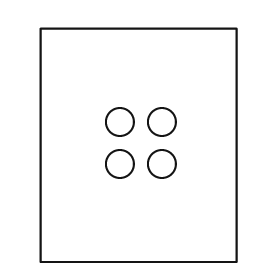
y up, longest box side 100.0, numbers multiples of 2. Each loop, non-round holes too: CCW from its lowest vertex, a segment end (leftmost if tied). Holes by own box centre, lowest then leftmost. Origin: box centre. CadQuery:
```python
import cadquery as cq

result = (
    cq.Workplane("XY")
    .moveTo(-42.0, -50.0)
    .lineTo(42.0, -50.0)
    .lineTo(42.0, 50.0)
    .lineTo(-42.0, 50.0)
    .close()
    .moveTo(-8.0, -8.0)
    .circle(6.0)
    .moveTo(10.0, -8.0)
    .circle(6.0)
    .moveTo(-8.0, 10.0)
    .circle(6.0)
    .moveTo(10.0, 10.0)
    .circle(6.0)
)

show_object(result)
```